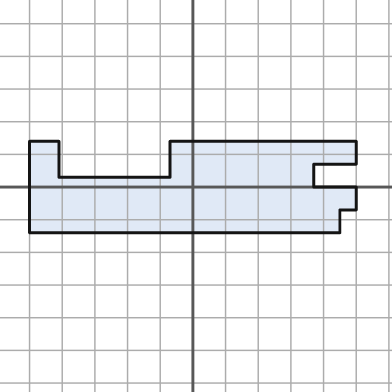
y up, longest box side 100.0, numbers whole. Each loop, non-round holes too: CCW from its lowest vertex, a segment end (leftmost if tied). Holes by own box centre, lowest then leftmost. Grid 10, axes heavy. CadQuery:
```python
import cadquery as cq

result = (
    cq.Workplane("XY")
    .moveTo(-50.0, -14.0)
    .lineTo(45.0, -14.0)
    .lineTo(45.0, -7.0)
    .lineTo(50.0, -7.0)
    .lineTo(50.0, 0.0)
    .lineTo(37.0, 0.0)
    .lineTo(37.0, 7.0)
    .lineTo(50.0, 7.0)
    .lineTo(50.0, 14.0)
    .lineTo(-7.0, 14.0)
    .lineTo(-7.0, 3.0)
    .lineTo(-41.0, 3.0)
    .lineTo(-41.0, 14.0)
    .lineTo(-50.0, 14.0)
    .close()
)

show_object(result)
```